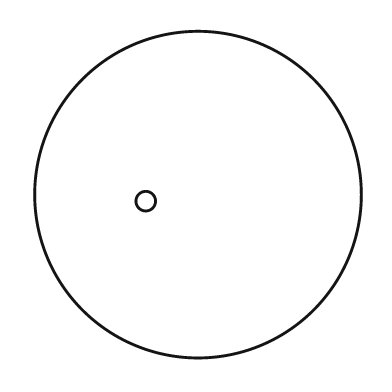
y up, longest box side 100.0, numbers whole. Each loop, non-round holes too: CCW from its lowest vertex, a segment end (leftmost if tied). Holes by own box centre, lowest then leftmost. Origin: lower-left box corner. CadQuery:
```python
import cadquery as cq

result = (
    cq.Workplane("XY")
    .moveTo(50.0, 50.0)
    .circle(50.0)
    .moveTo(34.0, 48.0)
    .circle(3.0)
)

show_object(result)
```